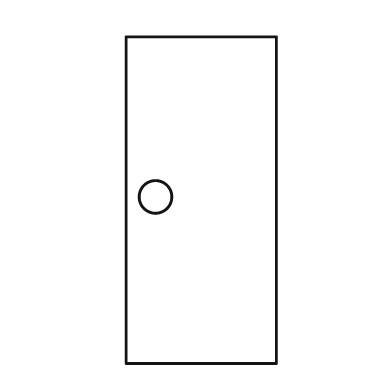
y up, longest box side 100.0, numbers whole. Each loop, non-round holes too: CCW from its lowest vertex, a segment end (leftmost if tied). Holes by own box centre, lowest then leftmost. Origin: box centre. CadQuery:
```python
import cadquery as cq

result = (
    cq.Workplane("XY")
    .moveTo(-23.0, -50.0)
    .lineTo(23.0, -50.0)
    .lineTo(23.0, 50.0)
    .lineTo(-23.0, 50.0)
    .close()
    .moveTo(-14.0, 1.0)
    .circle(5.0)
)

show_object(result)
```